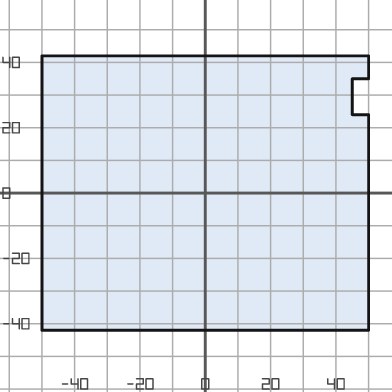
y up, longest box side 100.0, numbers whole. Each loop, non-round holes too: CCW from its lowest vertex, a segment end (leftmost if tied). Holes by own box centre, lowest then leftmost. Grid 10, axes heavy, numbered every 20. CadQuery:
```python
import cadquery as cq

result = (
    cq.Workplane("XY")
    .moveTo(-50.0, -42.0)
    .lineTo(50.0, -42.0)
    .lineTo(50.0, 24.0)
    .lineTo(45.0, 24.0)
    .lineTo(45.0, 35.0)
    .lineTo(50.0, 35.0)
    .lineTo(50.0, 42.0)
    .lineTo(-50.0, 42.0)
    .close()
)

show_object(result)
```